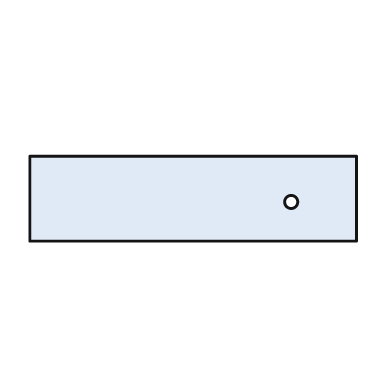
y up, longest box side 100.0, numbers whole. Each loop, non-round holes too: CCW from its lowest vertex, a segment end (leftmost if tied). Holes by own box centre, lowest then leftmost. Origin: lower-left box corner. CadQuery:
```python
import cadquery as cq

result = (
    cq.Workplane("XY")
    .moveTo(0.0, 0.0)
    .lineTo(100.0, 0.0)
    .lineTo(100.0, 26.0)
    .lineTo(0.0, 26.0)
    .close()
    .moveTo(80.0, 12.0)
    .circle(2.0)
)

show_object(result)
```